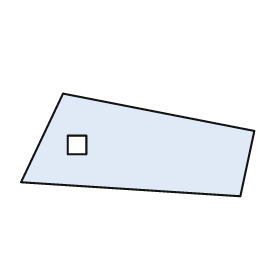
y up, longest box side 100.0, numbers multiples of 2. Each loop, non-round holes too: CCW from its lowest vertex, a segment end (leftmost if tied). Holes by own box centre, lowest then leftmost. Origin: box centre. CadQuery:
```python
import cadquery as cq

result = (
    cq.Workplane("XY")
    .moveTo(44.0, -22.0)
    .lineTo(50.0, 6.0)
    .lineTo(-32.0, 22.0)
    .lineTo(-50.0, -16.0)
    .close()
    .moveTo(-30.0, -4.0)
    .lineTo(-22.0, -4.0)
    .lineTo(-22.0, 4.0)
    .lineTo(-30.0, 4.0)
    .close()
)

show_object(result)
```